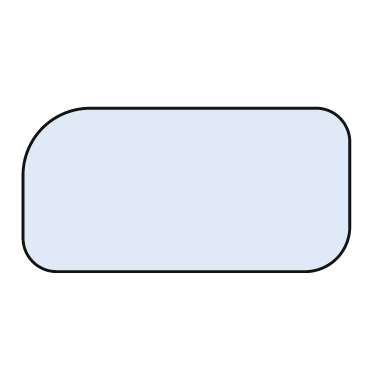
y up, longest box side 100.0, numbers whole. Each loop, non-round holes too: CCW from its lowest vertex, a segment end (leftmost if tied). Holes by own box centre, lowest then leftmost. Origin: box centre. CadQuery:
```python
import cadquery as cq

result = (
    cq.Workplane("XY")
    .moveTo(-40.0, -25.0)
    .lineTo(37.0, -25.0)
    .threePointArc((46.0, -21.0), (50.0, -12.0))
    .lineTo(50.0, 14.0)
    .threePointArc((47.0, 22.0), (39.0, 25.0))
    .lineTo(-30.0, 25.0)
    .threePointArc((-44.0, 19.0), (-50.0, 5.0))
    .lineTo(-50.0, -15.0)
    .threePointArc((-47.0, -22.0), (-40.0, -25.0))
    .close()
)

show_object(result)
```